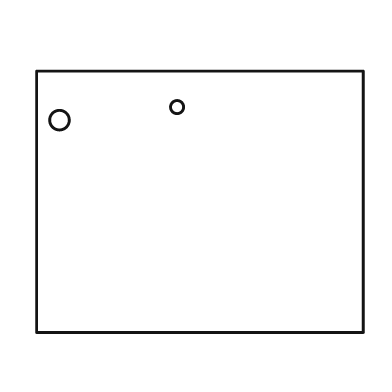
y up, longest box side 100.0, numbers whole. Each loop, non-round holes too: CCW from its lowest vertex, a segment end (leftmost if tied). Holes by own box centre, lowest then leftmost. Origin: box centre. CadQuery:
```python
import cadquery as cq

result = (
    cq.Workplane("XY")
    .moveTo(-50.0, -40.0)
    .lineTo(50.0, -40.0)
    .lineTo(50.0, 40.0)
    .lineTo(-50.0, 40.0)
    .close()
    .moveTo(-43.0, 25.0)
    .circle(3.0)
    .moveTo(-7.0, 29.0)
    .circle(2.0)
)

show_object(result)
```